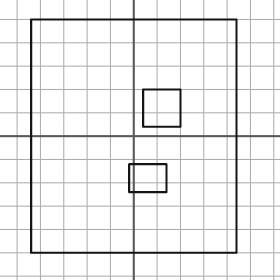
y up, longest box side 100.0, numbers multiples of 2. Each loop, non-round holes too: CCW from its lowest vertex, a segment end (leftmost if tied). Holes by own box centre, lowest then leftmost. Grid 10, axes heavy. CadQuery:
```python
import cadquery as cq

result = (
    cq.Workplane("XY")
    .moveTo(-44.0, -50.0)
    .lineTo(44.0, -50.0)
    .lineTo(44.0, 50.0)
    .lineTo(-44.0, 50.0)
    .close()
    .moveTo(-2.0, -24.0)
    .lineTo(14.0, -24.0)
    .lineTo(14.0, -12.0)
    .lineTo(-2.0, -12.0)
    .close()
    .moveTo(4.0, 4.0)
    .lineTo(20.0, 4.0)
    .lineTo(20.0, 20.0)
    .lineTo(4.0, 20.0)
    .close()
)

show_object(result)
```